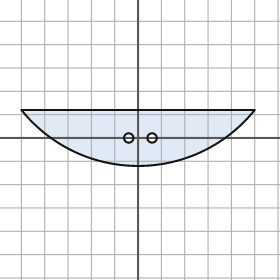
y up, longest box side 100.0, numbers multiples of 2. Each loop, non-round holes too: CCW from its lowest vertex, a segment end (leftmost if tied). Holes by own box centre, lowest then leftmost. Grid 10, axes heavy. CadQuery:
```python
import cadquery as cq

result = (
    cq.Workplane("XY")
    .moveTo(-50.0, 12.0)
    .threePointArc((0.0, -12.0), (50.0, 12.0))
    .close()
    .moveTo(-4.0, 0.0)
    .circle(2.0)
    .moveTo(6.0, 0.0)
    .circle(2.0)
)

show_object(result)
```